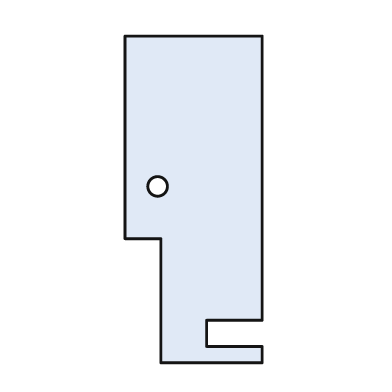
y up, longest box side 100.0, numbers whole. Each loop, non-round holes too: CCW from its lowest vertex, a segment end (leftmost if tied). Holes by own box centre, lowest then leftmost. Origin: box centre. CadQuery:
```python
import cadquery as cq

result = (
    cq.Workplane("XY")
    .moveTo(-10.0, -50.0)
    .lineTo(21.0, -50.0)
    .lineTo(21.0, -45.0)
    .lineTo(4.0, -45.0)
    .lineTo(4.0, -37.0)
    .lineTo(21.0, -37.0)
    .lineTo(21.0, 50.0)
    .lineTo(-21.0, 50.0)
    .lineTo(-21.0, -12.0)
    .lineTo(-10.0, -12.0)
    .close()
    .moveTo(-11.0, 4.0)
    .circle(3.0)
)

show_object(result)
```